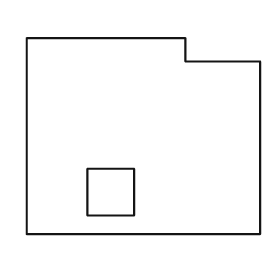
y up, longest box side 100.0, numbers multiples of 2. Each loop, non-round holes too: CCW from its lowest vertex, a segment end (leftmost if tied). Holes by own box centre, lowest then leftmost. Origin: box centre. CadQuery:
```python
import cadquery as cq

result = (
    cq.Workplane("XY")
    .moveTo(-50.0, -42.0)
    .lineTo(50.0, -42.0)
    .lineTo(50.0, 32.0)
    .lineTo(18.0, 32.0)
    .lineTo(18.0, 42.0)
    .lineTo(-50.0, 42.0)
    .close()
    .moveTo(-24.0, -34.0)
    .lineTo(-4.0, -34.0)
    .lineTo(-4.0, -14.0)
    .lineTo(-24.0, -14.0)
    .close()
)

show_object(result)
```